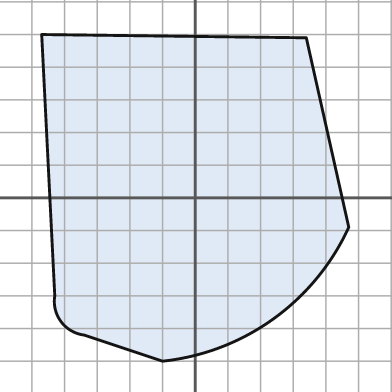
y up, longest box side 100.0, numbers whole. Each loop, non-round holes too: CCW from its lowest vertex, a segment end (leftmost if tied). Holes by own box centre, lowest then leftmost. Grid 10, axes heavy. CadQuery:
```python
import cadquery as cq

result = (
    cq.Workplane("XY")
    .moveTo(-10.0, -50.0)
    .threePointArc((24.0, -37.0), (47.0, -9.0))
    .lineTo(34.0, 49.0)
    .lineTo(-47.0, 50.0)
    .lineTo(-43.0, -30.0)
    .threePointArc((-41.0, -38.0), (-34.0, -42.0))
    .close()
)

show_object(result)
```